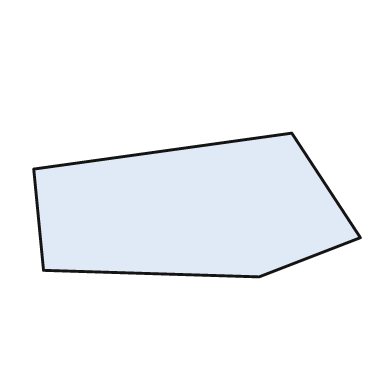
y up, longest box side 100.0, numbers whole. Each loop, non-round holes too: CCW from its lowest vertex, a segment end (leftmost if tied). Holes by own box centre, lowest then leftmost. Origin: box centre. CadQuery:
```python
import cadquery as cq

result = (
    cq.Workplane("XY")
    .moveTo(19.0, -22.0)
    .lineTo(50.0, -10.0)
    .lineTo(29.0, 22.0)
    .lineTo(-50.0, 11.0)
    .lineTo(-47.0, -20.0)
    .close()
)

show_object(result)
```